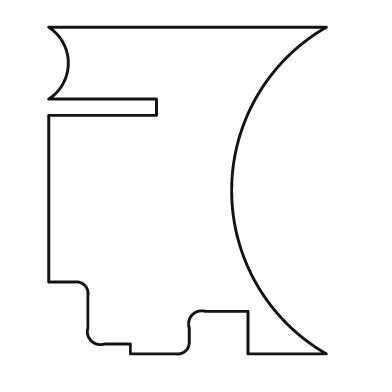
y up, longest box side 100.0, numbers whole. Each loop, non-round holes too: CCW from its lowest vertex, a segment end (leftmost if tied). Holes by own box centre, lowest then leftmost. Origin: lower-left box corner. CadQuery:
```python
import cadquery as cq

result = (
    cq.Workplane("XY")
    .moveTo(25.0, 0.0)
    .lineTo(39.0, 0.0)
    .threePointArc((42.0, 1.0), (43.0, 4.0))
    .lineTo(43.0, 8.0)
    .threePointArc((44.0, 12.0), (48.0, 13.0))
    .lineTo(61.0, 13.0)
    .lineTo(61.0, 0.0)
    .lineTo(85.0, 0.0)
    .threePointArc((56.0, 50.0), (85.0, 100.0))
    .lineTo(0.0, 100.0)
    .threePointArc((6.0, 89.0), (0.0, 78.0))
    .lineTo(33.0, 78.0)
    .lineTo(33.0, 73.0)
    .lineTo(0.0, 73.0)
    .lineTo(0.0, 22.0)
    .lineTo(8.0, 22.0)
    .threePointArc((11.0, 21.0), (12.0, 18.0))
    .lineTo(12.0, 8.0)
    .threePointArc((13.0, 4.0), (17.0, 3.0))
    .lineTo(25.0, 3.0)
    .close()
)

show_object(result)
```